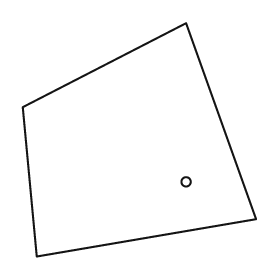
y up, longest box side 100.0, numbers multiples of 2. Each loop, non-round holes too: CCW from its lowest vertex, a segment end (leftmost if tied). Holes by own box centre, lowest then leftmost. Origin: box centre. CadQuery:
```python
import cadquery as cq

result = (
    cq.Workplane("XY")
    .moveTo(-44.0, -50.0)
    .lineTo(50.0, -34.0)
    .lineTo(20.0, 50.0)
    .lineTo(-50.0, 14.0)
    .close()
    .moveTo(20.0, -18.0)
    .circle(2.0)
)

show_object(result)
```